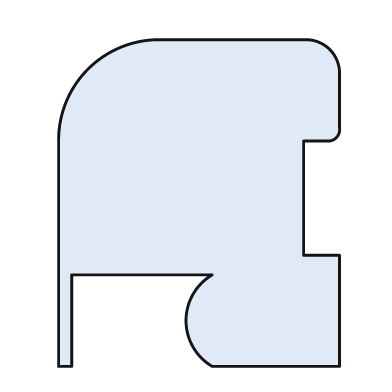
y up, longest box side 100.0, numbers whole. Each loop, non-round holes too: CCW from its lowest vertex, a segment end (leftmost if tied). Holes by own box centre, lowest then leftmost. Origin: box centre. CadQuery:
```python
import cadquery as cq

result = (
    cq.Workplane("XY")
    .moveTo(-43.0, -50.0)
    .lineTo(-39.0, -50.0)
    .lineTo(-39.0, -22.0)
    .lineTo(4.0, -22.0)
    .threePointArc((-4.0, -36.0), (4.0, -50.0))
    .lineTo(43.0, -50.0)
    .lineTo(43.0, -16.0)
    .lineTo(32.0, -16.0)
    .lineTo(32.0, 19.0)
    .lineTo(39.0, 19.0)
    .threePointArc((42.0, 20.0), (43.0, 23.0))
    .lineTo(43.0, 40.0)
    .threePointArc((40.0, 47.0), (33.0, 50.0))
    .lineTo(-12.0, 50.0)
    .threePointArc((-34.0, 41.0), (-43.0, 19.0))
    .close()
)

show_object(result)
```